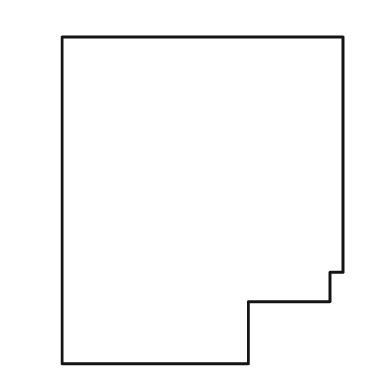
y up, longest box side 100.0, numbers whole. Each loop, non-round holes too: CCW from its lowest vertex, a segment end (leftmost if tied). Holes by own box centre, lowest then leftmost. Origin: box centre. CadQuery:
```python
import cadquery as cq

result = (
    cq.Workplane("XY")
    .moveTo(-43.0, -50.0)
    .lineTo(14.0, -50.0)
    .lineTo(14.0, -31.0)
    .lineTo(39.0, -31.0)
    .lineTo(39.0, -22.0)
    .lineTo(43.0, -22.0)
    .lineTo(43.0, 50.0)
    .lineTo(-43.0, 50.0)
    .close()
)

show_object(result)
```